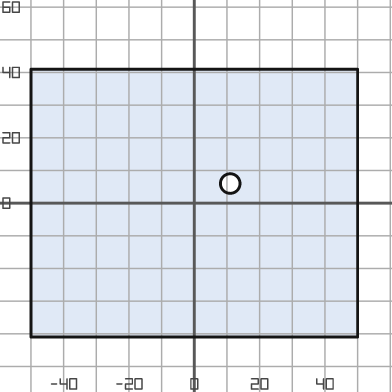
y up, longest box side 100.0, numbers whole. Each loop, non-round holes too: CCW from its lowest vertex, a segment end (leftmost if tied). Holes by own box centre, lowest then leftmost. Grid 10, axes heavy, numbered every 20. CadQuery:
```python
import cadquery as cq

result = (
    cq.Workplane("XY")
    .moveTo(-50.0, -41.0)
    .lineTo(50.0, -41.0)
    .lineTo(50.0, 41.0)
    .lineTo(-50.0, 41.0)
    .close()
    .moveTo(11.0, 6.0)
    .circle(3.0)
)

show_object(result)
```